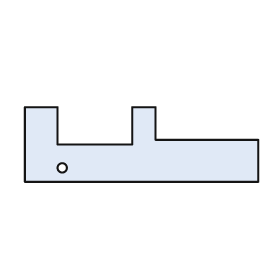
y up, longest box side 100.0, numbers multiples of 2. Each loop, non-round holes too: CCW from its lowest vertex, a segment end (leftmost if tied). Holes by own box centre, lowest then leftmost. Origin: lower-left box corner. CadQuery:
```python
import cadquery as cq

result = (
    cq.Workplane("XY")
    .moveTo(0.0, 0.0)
    .lineTo(100.0, 0.0)
    .lineTo(100.0, 18.0)
    .lineTo(56.0, 18.0)
    .lineTo(56.0, 32.0)
    .lineTo(46.0, 32.0)
    .lineTo(46.0, 16.0)
    .lineTo(14.0, 16.0)
    .lineTo(14.0, 32.0)
    .lineTo(0.0, 32.0)
    .close()
    .moveTo(16.0, 6.0)
    .circle(2.0)
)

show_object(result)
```